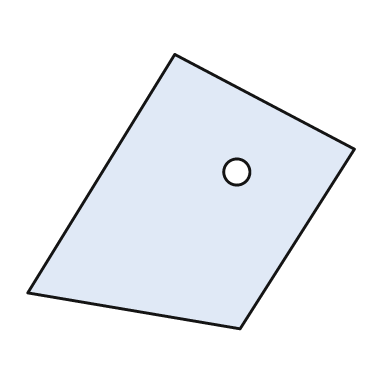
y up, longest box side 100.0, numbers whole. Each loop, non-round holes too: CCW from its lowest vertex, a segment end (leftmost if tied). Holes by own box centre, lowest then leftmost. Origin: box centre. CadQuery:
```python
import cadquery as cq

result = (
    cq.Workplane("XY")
    .moveTo(15.0, -42.0)
    .lineTo(50.0, 13.0)
    .lineTo(-5.0, 42.0)
    .lineTo(-50.0, -31.0)
    .close()
    .moveTo(14.0, 6.0)
    .circle(4.0)
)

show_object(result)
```